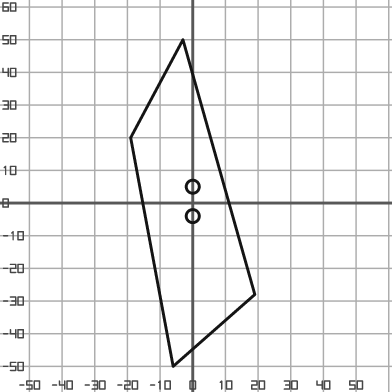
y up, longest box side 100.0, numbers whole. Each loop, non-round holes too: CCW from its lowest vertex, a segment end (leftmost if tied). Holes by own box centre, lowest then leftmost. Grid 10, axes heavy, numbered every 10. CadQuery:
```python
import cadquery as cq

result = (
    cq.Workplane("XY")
    .moveTo(-6.0, -50.0)
    .lineTo(19.0, -28.0)
    .lineTo(-3.0, 50.0)
    .lineTo(-19.0, 20.0)
    .close()
    .moveTo(0.0, -4.0)
    .circle(2.0)
    .moveTo(0.0, 5.0)
    .circle(2.0)
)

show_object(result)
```